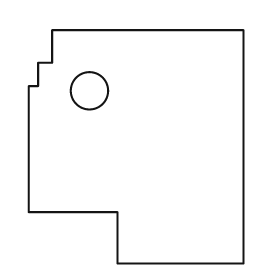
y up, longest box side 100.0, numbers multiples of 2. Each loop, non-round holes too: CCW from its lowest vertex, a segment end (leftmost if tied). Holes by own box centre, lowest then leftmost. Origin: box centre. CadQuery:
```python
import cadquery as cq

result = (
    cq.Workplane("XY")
    .moveTo(-8.0, -50.0)
    .lineTo(46.0, -50.0)
    .lineTo(46.0, 50.0)
    .lineTo(-36.0, 50.0)
    .lineTo(-36.0, 36.0)
    .lineTo(-42.0, 36.0)
    .lineTo(-42.0, 26.0)
    .lineTo(-46.0, 26.0)
    .lineTo(-46.0, -28.0)
    .lineTo(-8.0, -28.0)
    .close()
    .moveTo(-20.0, 24.0)
    .circle(8.0)
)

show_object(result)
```